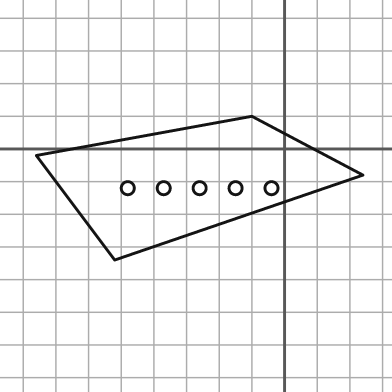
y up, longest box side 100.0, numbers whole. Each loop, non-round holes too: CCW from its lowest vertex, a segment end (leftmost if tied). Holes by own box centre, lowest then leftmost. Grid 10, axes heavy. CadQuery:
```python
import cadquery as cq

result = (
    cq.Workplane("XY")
    .moveTo(-52.0, -34.0)
    .lineTo(24.0, -8.0)
    .lineTo(-10.0, 10.0)
    .lineTo(-76.0, -2.0)
    .close()
    .moveTo(-48.0, -12.0)
    .circle(2.0)
    .moveTo(-37.0, -12.0)
    .circle(2.0)
    .moveTo(-26.0, -12.0)
    .circle(2.0)
    .moveTo(-15.0, -12.0)
    .circle(2.0)
    .moveTo(-4.0, -12.0)
    .circle(2.0)
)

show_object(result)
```